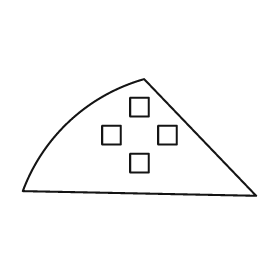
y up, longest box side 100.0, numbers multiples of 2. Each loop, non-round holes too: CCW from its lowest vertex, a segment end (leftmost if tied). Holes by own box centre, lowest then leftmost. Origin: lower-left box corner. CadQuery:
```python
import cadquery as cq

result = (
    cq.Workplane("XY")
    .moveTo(100.0, 0.0)
    .lineTo(52.0, 50.0)
    .threePointArc((20.0, 32.0), (0.0, 2.0))
    .close()
    .moveTo(46.0, 10.0)
    .lineTo(54.0, 10.0)
    .lineTo(54.0, 18.0)
    .lineTo(46.0, 18.0)
    .close()
    .moveTo(34.0, 22.0)
    .lineTo(42.0, 22.0)
    .lineTo(42.0, 30.0)
    .lineTo(34.0, 30.0)
    .close()
    .moveTo(58.0, 22.0)
    .lineTo(66.0, 22.0)
    .lineTo(66.0, 30.0)
    .lineTo(58.0, 30.0)
    .close()
    .moveTo(46.0, 34.0)
    .lineTo(54.0, 34.0)
    .lineTo(54.0, 42.0)
    .lineTo(46.0, 42.0)
    .close()
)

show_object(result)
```